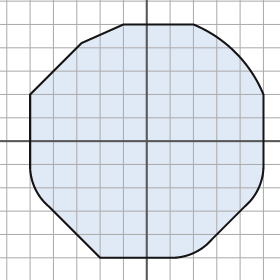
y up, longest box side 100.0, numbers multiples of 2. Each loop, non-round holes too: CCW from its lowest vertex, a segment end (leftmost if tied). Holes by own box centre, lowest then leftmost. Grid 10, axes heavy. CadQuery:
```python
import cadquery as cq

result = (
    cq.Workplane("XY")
    .moveTo(-20.0, -50.0)
    .lineTo(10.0, -50.0)
    .threePointArc((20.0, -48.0), (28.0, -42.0))
    .lineTo(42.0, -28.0)
    .threePointArc((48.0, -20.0), (50.0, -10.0))
    .lineTo(50.0, 20.0)
    .threePointArc((38.0, 38.0), (20.0, 50.0))
    .lineTo(-10.0, 50.0)
    .lineTo(-28.0, 42.0)
    .lineTo(-50.0, 20.0)
    .lineTo(-50.0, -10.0)
    .threePointArc((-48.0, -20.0), (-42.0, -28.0))
    .close()
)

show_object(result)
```